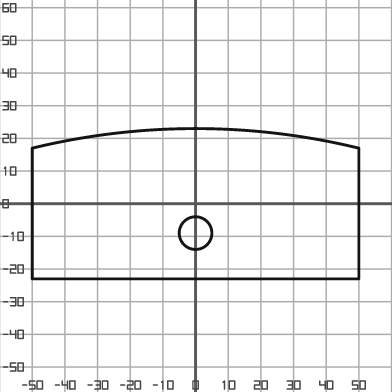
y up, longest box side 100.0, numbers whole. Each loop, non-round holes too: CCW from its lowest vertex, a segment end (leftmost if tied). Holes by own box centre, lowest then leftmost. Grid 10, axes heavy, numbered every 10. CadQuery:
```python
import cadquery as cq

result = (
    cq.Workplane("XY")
    .moveTo(-50.0, -23.0)
    .lineTo(50.0, -23.0)
    .lineTo(50.0, 17.0)
    .threePointArc((0.0, 23.0), (-50.0, 17.0))
    .close()
    .moveTo(0.0, -9.0)
    .circle(5.0)
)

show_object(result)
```